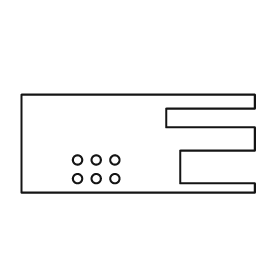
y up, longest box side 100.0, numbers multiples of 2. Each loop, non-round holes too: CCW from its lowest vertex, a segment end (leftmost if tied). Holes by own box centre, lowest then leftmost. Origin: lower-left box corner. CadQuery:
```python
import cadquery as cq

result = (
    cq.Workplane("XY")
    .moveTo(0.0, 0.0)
    .lineTo(100.0, 0.0)
    .lineTo(100.0, 4.0)
    .lineTo(68.0, 4.0)
    .lineTo(68.0, 18.0)
    .lineTo(100.0, 18.0)
    .lineTo(100.0, 28.0)
    .lineTo(62.0, 28.0)
    .lineTo(62.0, 36.0)
    .lineTo(100.0, 36.0)
    .lineTo(100.0, 42.0)
    .lineTo(0.0, 42.0)
    .close()
    .moveTo(24.0, 6.0)
    .circle(2.0)
    .moveTo(32.0, 6.0)
    .circle(2.0)
    .moveTo(40.0, 6.0)
    .circle(2.0)
    .moveTo(24.0, 14.0)
    .circle(2.0)
    .moveTo(32.0, 14.0)
    .circle(2.0)
    .moveTo(40.0, 14.0)
    .circle(2.0)
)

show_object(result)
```